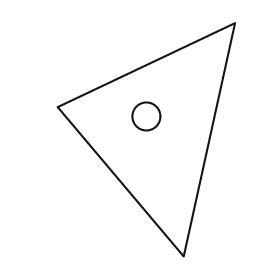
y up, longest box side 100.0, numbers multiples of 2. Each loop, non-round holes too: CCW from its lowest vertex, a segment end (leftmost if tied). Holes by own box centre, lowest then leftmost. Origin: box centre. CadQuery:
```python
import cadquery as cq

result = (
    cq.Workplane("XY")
    .moveTo(16.0, -50.0)
    .lineTo(38.0, 50.0)
    .lineTo(-38.0, 14.0)
    .close()
    .moveTo(0.0, 10.0)
    .circle(6.0)
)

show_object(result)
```